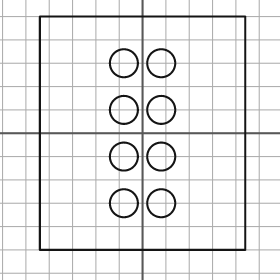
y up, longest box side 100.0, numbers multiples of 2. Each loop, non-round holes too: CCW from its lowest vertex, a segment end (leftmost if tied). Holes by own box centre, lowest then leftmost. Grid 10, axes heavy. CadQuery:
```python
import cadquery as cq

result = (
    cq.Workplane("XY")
    .moveTo(-44.0, -50.0)
    .lineTo(44.0, -50.0)
    .lineTo(44.0, 50.0)
    .lineTo(-44.0, 50.0)
    .close()
    .moveTo(-8.0, -30.0)
    .circle(6.0)
    .moveTo(8.0, -30.0)
    .circle(6.0)
    .moveTo(-8.0, -10.0)
    .circle(6.0)
    .moveTo(8.0, -10.0)
    .circle(6.0)
    .moveTo(-8.0, 10.0)
    .circle(6.0)
    .moveTo(8.0, 10.0)
    .circle(6.0)
    .moveTo(-8.0, 30.0)
    .circle(6.0)
    .moveTo(8.0, 30.0)
    .circle(6.0)
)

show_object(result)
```